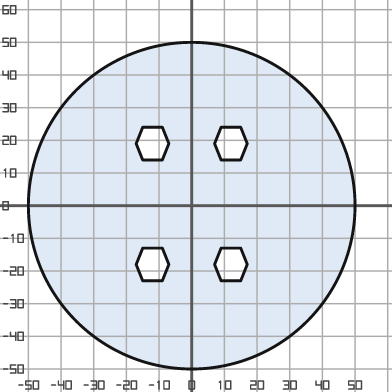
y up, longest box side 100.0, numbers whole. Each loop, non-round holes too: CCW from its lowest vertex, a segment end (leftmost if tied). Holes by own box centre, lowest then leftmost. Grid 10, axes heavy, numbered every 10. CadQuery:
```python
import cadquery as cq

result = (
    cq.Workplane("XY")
    .moveTo(0.0, 0.0)
    .circle(50.0)
    .moveTo(-15.0, -23.0)
    .lineTo(-9.0, -23.0)
    .lineTo(-7.0, -18.0)
    .lineTo(-9.0, -13.0)
    .lineTo(-15.0, -13.0)
    .lineTo(-17.0, -18.0)
    .close()
    .moveTo(9.0, -23.0)
    .lineTo(15.0, -23.0)
    .lineTo(17.0, -18.0)
    .lineTo(15.0, -13.0)
    .lineTo(9.0, -13.0)
    .lineTo(7.0, -18.0)
    .close()
    .moveTo(-15.0, 14.0)
    .lineTo(-9.0, 14.0)
    .lineTo(-7.0, 19.0)
    .lineTo(-9.0, 24.0)
    .lineTo(-15.0, 24.0)
    .lineTo(-17.0, 19.0)
    .close()
    .moveTo(9.0, 14.0)
    .lineTo(15.0, 14.0)
    .lineTo(17.0, 19.0)
    .lineTo(15.0, 24.0)
    .lineTo(9.0, 24.0)
    .lineTo(7.0, 19.0)
    .close()
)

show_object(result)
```